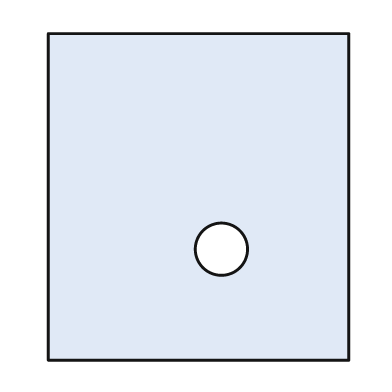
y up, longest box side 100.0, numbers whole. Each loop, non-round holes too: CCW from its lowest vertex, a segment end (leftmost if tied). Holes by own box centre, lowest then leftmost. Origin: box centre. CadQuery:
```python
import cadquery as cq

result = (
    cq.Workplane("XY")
    .moveTo(-46.0, -50.0)
    .lineTo(46.0, -50.0)
    .lineTo(46.0, 50.0)
    .lineTo(-46.0, 50.0)
    .close()
    .moveTo(7.0, -16.0)
    .circle(8.0)
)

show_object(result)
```